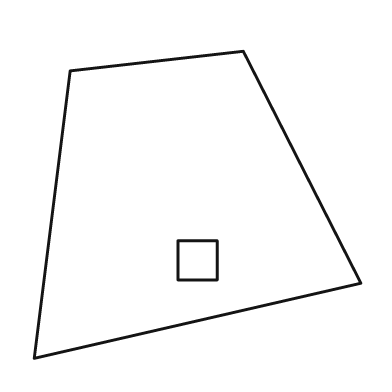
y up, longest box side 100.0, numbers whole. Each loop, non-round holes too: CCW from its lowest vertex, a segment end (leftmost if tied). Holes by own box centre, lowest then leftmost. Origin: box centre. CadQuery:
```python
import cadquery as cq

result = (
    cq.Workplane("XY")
    .moveTo(-50.0, -47.0)
    .lineTo(50.0, -24.0)
    .lineTo(14.0, 47.0)
    .lineTo(-39.0, 41.0)
    .close()
    .moveTo(-6.0, -23.0)
    .lineTo(6.0, -23.0)
    .lineTo(6.0, -11.0)
    .lineTo(-6.0, -11.0)
    .close()
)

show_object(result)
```